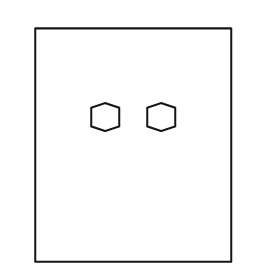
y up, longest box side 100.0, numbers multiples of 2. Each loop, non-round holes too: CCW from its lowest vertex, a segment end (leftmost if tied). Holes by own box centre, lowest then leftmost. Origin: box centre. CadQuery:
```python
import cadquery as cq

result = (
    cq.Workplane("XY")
    .moveTo(-42.0, -50.0)
    .lineTo(42.0, -50.0)
    .lineTo(42.0, 50.0)
    .lineTo(-42.0, 50.0)
    .close()
    .moveTo(-12.0, 6.0)
    .lineTo(-6.0, 8.0)
    .lineTo(-6.0, 16.0)
    .lineTo(-12.0, 18.0)
    .lineTo(-18.0, 16.0)
    .lineTo(-18.0, 8.0)
    .close()
    .moveTo(12.0, 6.0)
    .lineTo(18.0, 8.0)
    .lineTo(18.0, 16.0)
    .lineTo(12.0, 18.0)
    .lineTo(6.0, 16.0)
    .lineTo(6.0, 8.0)
    .close()
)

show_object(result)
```